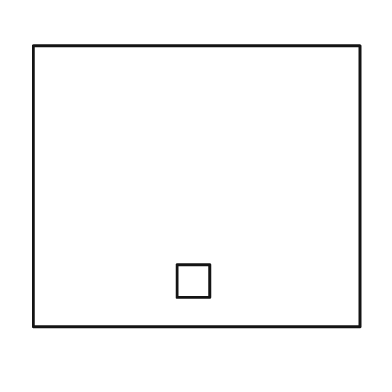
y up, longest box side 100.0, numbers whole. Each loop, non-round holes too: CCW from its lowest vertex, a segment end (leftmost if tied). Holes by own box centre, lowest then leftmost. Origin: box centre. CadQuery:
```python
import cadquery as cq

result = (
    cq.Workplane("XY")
    .moveTo(-50.0, -43.0)
    .lineTo(50.0, -43.0)
    .lineTo(50.0, 43.0)
    .lineTo(-50.0, 43.0)
    .close()
    .moveTo(-6.0, -34.0)
    .lineTo(4.0, -34.0)
    .lineTo(4.0, -24.0)
    .lineTo(-6.0, -24.0)
    .close()
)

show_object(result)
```